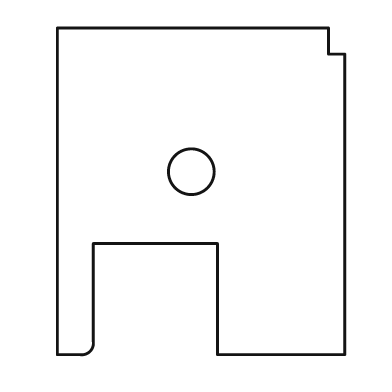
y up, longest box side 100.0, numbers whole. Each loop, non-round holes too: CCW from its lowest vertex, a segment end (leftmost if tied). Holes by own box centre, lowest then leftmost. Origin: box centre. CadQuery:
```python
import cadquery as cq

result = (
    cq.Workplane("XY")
    .moveTo(-44.0, -50.0)
    .lineTo(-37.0, -50.0)
    .threePointArc((-34.0, -49.0), (-33.0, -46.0))
    .lineTo(-33.0, -16.0)
    .lineTo(5.0, -16.0)
    .lineTo(5.0, -50.0)
    .lineTo(44.0, -50.0)
    .lineTo(44.0, 42.0)
    .lineTo(39.0, 42.0)
    .lineTo(39.0, 50.0)
    .lineTo(-44.0, 50.0)
    .close()
    .moveTo(-3.0, 6.0)
    .circle(7.0)
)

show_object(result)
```